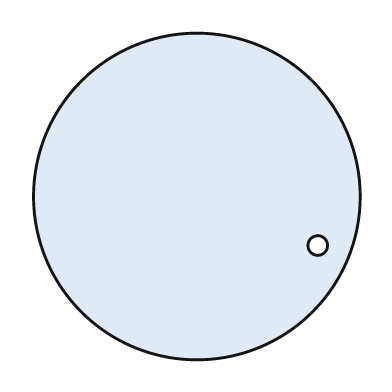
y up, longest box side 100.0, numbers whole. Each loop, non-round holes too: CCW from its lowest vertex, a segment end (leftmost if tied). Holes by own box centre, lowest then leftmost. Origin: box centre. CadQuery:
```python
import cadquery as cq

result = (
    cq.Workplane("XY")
    .moveTo(0.0, 0.0)
    .circle(50.0)
    .moveTo(37.0, -15.0)
    .circle(3.0)
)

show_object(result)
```